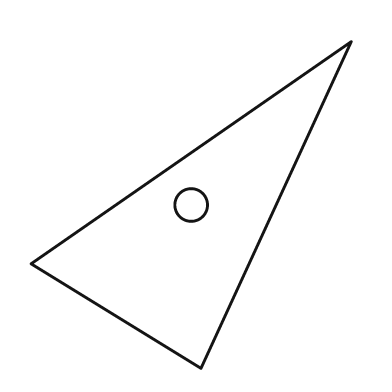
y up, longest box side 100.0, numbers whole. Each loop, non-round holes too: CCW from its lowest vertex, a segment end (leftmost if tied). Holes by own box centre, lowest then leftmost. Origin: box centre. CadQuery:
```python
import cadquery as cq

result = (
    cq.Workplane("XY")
    .moveTo(3.0, -50.0)
    .lineTo(49.0, 50.0)
    .lineTo(-49.0, -18.0)
    .close()
    .moveTo(0.0, 0.0)
    .circle(5.0)
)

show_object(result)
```